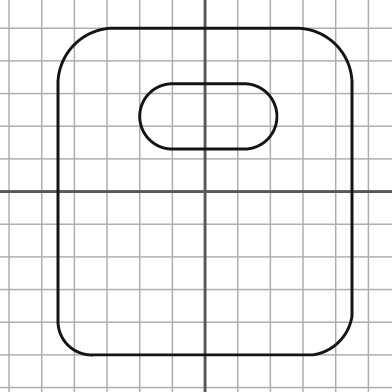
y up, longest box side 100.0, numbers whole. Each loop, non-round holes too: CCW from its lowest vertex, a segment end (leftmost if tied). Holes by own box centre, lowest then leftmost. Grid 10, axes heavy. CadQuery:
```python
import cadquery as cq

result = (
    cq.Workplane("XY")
    .moveTo(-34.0, -50.0)
    .lineTo(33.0, -50.0)
    .threePointArc((41.0, -46.0), (45.0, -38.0))
    .lineTo(45.0, 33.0)
    .threePointArc((40.0, 45.0), (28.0, 50.0))
    .lineTo(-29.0, 50.0)
    .threePointArc((-40.0, 45.0), (-45.0, 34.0))
    .lineTo(-45.0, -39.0)
    .threePointArc((-42.0, -47.0), (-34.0, -50.0))
    .close()
    .moveTo(-10.0, 13.0)
    .lineTo(12.0, 13.0)
    .threePointArc((22.0, 23.0), (12.0, 33.0))
    .lineTo(-10.0, 33.0)
    .threePointArc((-20.0, 23.0), (-10.0, 13.0))
    .close()
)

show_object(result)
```